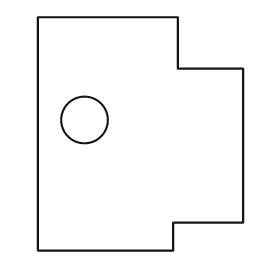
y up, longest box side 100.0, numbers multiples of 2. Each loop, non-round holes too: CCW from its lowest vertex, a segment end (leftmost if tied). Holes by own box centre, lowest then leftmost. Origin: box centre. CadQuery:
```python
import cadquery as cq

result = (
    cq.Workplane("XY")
    .moveTo(-44.0, -50.0)
    .lineTo(14.0, -50.0)
    .lineTo(14.0, -38.0)
    .lineTo(44.0, -38.0)
    .lineTo(44.0, 28.0)
    .lineTo(16.0, 28.0)
    .lineTo(16.0, 50.0)
    .lineTo(-44.0, 50.0)
    .close()
    .moveTo(-24.0, 6.0)
    .circle(10.0)
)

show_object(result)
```